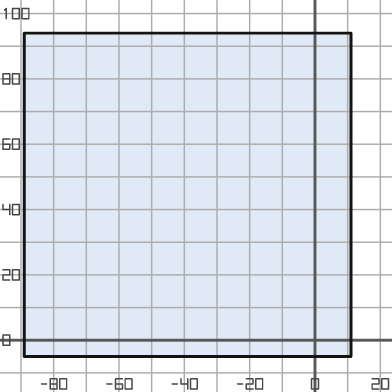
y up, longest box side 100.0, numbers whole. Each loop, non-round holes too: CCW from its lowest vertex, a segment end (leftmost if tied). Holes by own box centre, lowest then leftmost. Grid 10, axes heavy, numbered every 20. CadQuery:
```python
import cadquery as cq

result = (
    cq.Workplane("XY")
    .moveTo(-89.0, -5.0)
    .lineTo(11.0, -5.0)
    .lineTo(11.0, 94.0)
    .lineTo(-89.0, 94.0)
    .close()
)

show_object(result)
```